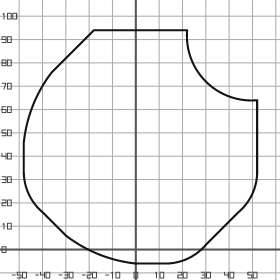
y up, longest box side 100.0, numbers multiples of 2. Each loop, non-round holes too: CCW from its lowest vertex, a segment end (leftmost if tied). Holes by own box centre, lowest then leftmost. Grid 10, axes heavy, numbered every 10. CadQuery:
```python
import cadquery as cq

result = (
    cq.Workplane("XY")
    .moveTo(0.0, -6.0)
    .lineTo(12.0, -6.0)
    .threePointArc((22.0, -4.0), (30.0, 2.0))
    .lineTo(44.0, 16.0)
    .threePointArc((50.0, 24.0), (52.0, 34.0))
    .lineTo(52.0, 64.0)
    .threePointArc((30.0, 72.0), (22.0, 94.0))
    .lineTo(-18.0, 94.0)
    .lineTo(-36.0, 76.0)
    .threePointArc((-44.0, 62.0), (-48.0, 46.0))
    .lineTo(-48.0, 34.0)
    .threePointArc((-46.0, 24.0), (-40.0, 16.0))
    .lineTo(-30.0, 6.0)
    .threePointArc((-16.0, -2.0), (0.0, -6.0))
    .close()
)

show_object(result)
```